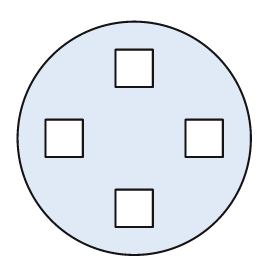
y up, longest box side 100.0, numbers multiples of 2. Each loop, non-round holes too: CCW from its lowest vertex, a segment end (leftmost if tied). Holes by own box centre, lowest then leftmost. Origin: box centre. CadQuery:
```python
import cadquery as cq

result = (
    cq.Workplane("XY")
    .moveTo(0.0, 0.0)
    .circle(50.0)
    .moveTo(-8.0, -38.0)
    .lineTo(8.0, -38.0)
    .lineTo(8.0, -22.0)
    .lineTo(-8.0, -22.0)
    .close()
    .moveTo(-38.0, -8.0)
    .lineTo(-22.0, -8.0)
    .lineTo(-22.0, 8.0)
    .lineTo(-38.0, 8.0)
    .close()
    .moveTo(22.0, -8.0)
    .lineTo(38.0, -8.0)
    .lineTo(38.0, 8.0)
    .lineTo(22.0, 8.0)
    .close()
    .moveTo(-8.0, 22.0)
    .lineTo(8.0, 22.0)
    .lineTo(8.0, 38.0)
    .lineTo(-8.0, 38.0)
    .close()
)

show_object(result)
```